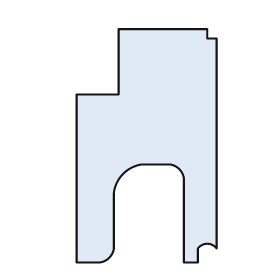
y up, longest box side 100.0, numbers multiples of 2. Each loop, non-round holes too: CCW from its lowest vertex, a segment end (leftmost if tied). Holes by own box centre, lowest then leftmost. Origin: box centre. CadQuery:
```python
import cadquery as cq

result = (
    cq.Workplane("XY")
    .moveTo(-30.0, -50.0)
    .lineTo(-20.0, -50.0)
    .threePointArc((-16.0, -48.0), (-14.0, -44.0))
    .lineTo(-14.0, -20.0)
    .threePointArc((-10.0, -12.0), (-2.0, -8.0))
    .lineTo(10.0, -8.0)
    .threePointArc((14.0, -10.0), (16.0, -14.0))
    .lineTo(16.0, -50.0)
    .lineTo(22.0, -50.0)
    .lineTo(22.0, -44.0)
    .threePointArc((26.0, -42.0), (30.0, -44.0))
    .lineTo(30.0, 46.0)
    .lineTo(26.0, 46.0)
    .lineTo(26.0, 50.0)
    .lineTo(-12.0, 50.0)
    .lineTo(-12.0, 22.0)
    .lineTo(-30.0, 22.0)
    .close()
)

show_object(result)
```